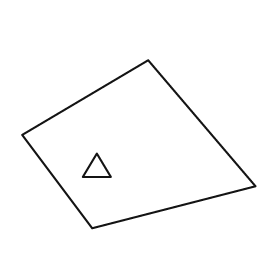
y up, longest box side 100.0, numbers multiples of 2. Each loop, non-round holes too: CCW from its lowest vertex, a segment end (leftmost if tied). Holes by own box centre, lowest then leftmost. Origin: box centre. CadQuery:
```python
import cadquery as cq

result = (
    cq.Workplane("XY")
    .moveTo(-20.0, -36.0)
    .lineTo(50.0, -18.0)
    .lineTo(4.0, 36.0)
    .lineTo(-50.0, 4.0)
    .close()
    .moveTo(-24.0, -14.0)
    .lineTo(-12.0, -14.0)
    .lineTo(-18.0, -4.0)
    .close()
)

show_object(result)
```